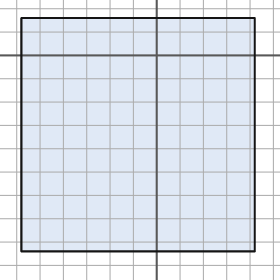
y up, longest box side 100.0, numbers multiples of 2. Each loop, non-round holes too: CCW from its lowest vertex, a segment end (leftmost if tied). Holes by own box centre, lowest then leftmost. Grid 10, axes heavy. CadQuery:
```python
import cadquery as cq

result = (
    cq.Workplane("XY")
    .moveTo(-58.0, -84.0)
    .lineTo(42.0, -84.0)
    .lineTo(42.0, 16.0)
    .lineTo(-58.0, 16.0)
    .close()
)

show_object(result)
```